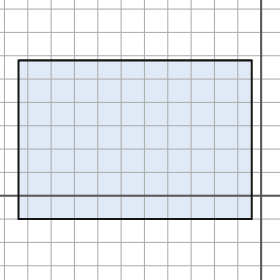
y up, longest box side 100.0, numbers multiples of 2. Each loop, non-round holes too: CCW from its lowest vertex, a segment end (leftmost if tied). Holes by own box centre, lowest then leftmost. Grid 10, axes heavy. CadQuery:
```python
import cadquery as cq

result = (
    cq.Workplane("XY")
    .moveTo(-104.0, -10.0)
    .lineTo(-4.0, -10.0)
    .lineTo(-4.0, 58.0)
    .lineTo(-104.0, 58.0)
    .close()
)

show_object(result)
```